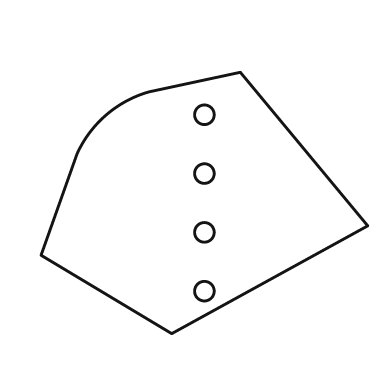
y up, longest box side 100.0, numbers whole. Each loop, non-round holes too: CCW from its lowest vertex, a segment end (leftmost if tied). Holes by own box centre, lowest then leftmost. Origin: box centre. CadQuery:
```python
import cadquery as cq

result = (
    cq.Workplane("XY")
    .moveTo(-10.0, -40.0)
    .lineTo(50.0, -7.0)
    .lineTo(11.0, 40.0)
    .lineTo(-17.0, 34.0)
    .threePointArc((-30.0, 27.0), (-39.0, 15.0))
    .lineTo(-50.0, -16.0)
    .close()
    .moveTo(0.0, -27.0)
    .circle(3.0)
    .moveTo(0.0, -9.0)
    .circle(3.0)
    .moveTo(0.0, 9.0)
    .circle(3.0)
    .moveTo(0.0, 27.0)
    .circle(3.0)
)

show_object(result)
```